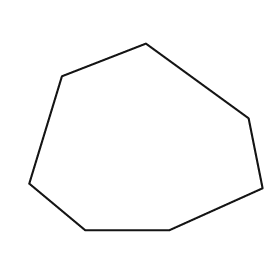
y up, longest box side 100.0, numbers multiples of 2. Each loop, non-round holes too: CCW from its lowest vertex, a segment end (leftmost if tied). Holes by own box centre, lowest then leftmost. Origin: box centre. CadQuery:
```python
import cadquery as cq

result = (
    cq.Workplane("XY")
    .moveTo(-26.0, -40.0)
    .lineTo(10.0, -40.0)
    .lineTo(50.0, -22.0)
    .lineTo(44.0, 8.0)
    .lineTo(0.0, 40.0)
    .lineTo(-36.0, 26.0)
    .lineTo(-50.0, -20.0)
    .close()
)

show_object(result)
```